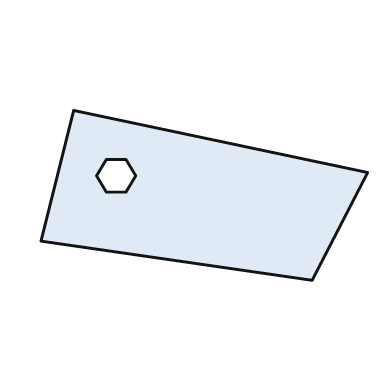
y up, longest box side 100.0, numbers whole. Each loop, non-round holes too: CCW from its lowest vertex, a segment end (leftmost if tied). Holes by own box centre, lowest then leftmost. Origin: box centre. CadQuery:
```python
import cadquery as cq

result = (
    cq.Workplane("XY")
    .moveTo(33.0, -26.0)
    .lineTo(50.0, 7.0)
    .lineTo(-40.0, 26.0)
    .lineTo(-50.0, -14.0)
    .close()
    .moveTo(-30.0, 1.0)
    .lineTo(-24.0, 1.0)
    .lineTo(-21.0, 6.0)
    .lineTo(-24.0, 11.0)
    .lineTo(-30.0, 11.0)
    .lineTo(-33.0, 6.0)
    .close()
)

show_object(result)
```